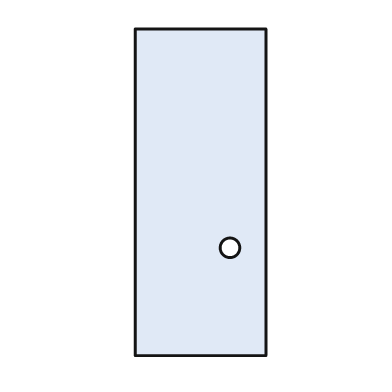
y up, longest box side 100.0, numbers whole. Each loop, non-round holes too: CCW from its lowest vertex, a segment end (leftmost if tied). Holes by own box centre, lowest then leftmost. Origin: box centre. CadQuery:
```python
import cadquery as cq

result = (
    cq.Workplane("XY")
    .moveTo(-20.0, -50.0)
    .lineTo(20.0, -50.0)
    .lineTo(20.0, 50.0)
    .lineTo(-20.0, 50.0)
    .close()
    .moveTo(9.0, -17.0)
    .circle(3.0)
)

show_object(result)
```